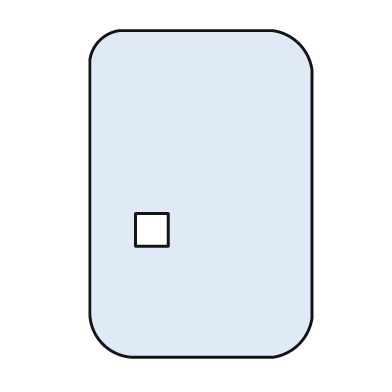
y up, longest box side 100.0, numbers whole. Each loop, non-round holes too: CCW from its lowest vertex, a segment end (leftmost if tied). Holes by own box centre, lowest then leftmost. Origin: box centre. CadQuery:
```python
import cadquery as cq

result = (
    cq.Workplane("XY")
    .moveTo(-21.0, -50.0)
    .lineTo(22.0, -50.0)
    .threePointArc((30.0, -46.0), (34.0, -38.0))
    .lineTo(34.0, 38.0)
    .threePointArc((30.0, 46.0), (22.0, 50.0))
    .lineTo(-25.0, 50.0)
    .threePointArc((-31.0, 47.0), (-34.0, 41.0))
    .lineTo(-34.0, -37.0)
    .threePointArc((-30.0, -46.0), (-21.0, -50.0))
    .close()
    .moveTo(-20.0, -16.0)
    .lineTo(-10.0, -16.0)
    .lineTo(-10.0, -6.0)
    .lineTo(-20.0, -6.0)
    .close()
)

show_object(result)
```